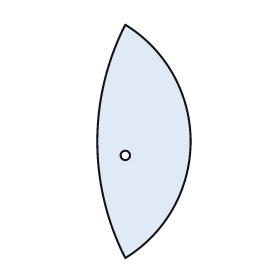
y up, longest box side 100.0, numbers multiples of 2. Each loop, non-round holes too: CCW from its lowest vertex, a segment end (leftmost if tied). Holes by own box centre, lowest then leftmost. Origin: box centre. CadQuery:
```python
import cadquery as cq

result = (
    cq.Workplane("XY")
    .moveTo(-8.0, -50.0)
    .threePointArc((20.0, 0.0), (-8.0, 50.0))
    .threePointArc((-20.0, 0.0), (-8.0, -50.0))
    .close()
    .moveTo(-8.0, -6.0)
    .circle(2.0)
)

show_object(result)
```